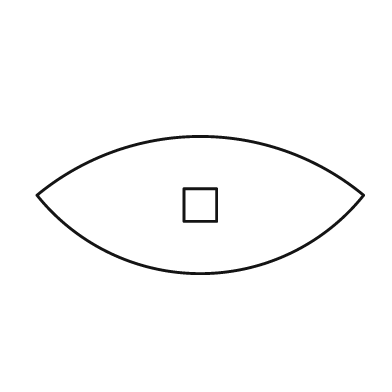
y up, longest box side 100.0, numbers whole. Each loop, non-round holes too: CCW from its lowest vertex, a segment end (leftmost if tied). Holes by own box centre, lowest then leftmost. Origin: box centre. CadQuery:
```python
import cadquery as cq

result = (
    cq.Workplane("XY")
    .moveTo(-50.0, 3.0)
    .threePointArc((0.0, -21.0), (50.0, 3.0))
    .threePointArc((0.0, 21.0), (-50.0, 3.0))
    .close()
    .moveTo(-5.0, -5.0)
    .lineTo(5.0, -5.0)
    .lineTo(5.0, 5.0)
    .lineTo(-5.0, 5.0)
    .close()
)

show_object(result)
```